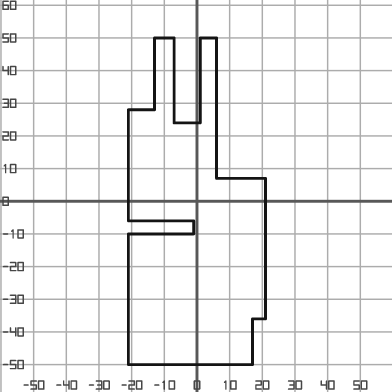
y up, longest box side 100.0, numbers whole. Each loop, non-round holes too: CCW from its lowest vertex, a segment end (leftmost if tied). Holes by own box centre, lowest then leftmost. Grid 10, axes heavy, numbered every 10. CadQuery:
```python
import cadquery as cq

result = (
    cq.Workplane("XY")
    .moveTo(-21.0, -50.0)
    .lineTo(17.0, -50.0)
    .lineTo(17.0, -36.0)
    .lineTo(21.0, -36.0)
    .lineTo(21.0, 7.0)
    .lineTo(6.0, 7.0)
    .lineTo(6.0, 50.0)
    .lineTo(1.0, 50.0)
    .lineTo(1.0, 24.0)
    .lineTo(-7.0, 24.0)
    .lineTo(-7.0, 50.0)
    .lineTo(-13.0, 50.0)
    .lineTo(-13.0, 28.0)
    .lineTo(-21.0, 28.0)
    .lineTo(-21.0, -6.0)
    .lineTo(-1.0, -6.0)
    .lineTo(-1.0, -10.0)
    .lineTo(-21.0, -10.0)
    .close()
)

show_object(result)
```